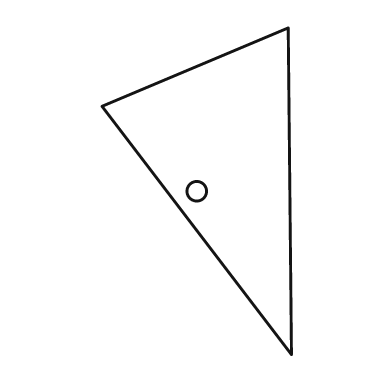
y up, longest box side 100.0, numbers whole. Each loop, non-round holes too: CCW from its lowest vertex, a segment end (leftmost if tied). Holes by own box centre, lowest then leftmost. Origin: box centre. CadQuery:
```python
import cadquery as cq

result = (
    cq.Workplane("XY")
    .moveTo(29.0, -50.0)
    .lineTo(28.0, 50.0)
    .lineTo(-29.0, 26.0)
    .close()
    .moveTo(0.0, 0.0)
    .circle(3.0)
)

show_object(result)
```